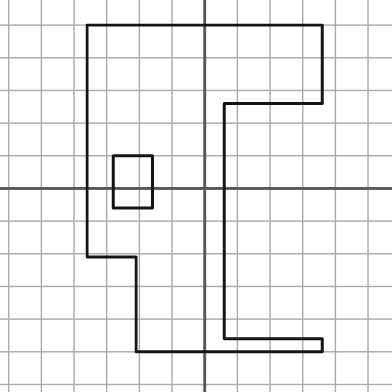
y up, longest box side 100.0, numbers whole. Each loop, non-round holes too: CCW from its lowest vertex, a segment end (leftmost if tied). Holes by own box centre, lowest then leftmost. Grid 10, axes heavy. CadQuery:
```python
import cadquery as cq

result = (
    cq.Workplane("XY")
    .moveTo(-21.0, -50.0)
    .lineTo(36.0, -50.0)
    .lineTo(36.0, -46.0)
    .lineTo(6.0, -46.0)
    .lineTo(6.0, 26.0)
    .lineTo(36.0, 26.0)
    .lineTo(36.0, 50.0)
    .lineTo(-36.0, 50.0)
    .lineTo(-36.0, -21.0)
    .lineTo(-21.0, -21.0)
    .close()
    .moveTo(-28.0, -6.0)
    .lineTo(-16.0, -6.0)
    .lineTo(-16.0, 10.0)
    .lineTo(-28.0, 10.0)
    .close()
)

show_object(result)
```